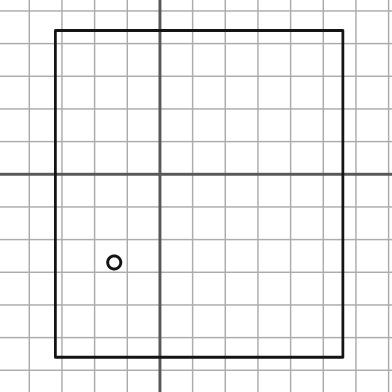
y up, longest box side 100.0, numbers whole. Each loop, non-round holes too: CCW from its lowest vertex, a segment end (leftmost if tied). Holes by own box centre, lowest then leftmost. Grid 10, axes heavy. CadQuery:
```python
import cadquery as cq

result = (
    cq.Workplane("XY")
    .moveTo(-32.0, -56.0)
    .lineTo(56.0, -56.0)
    .lineTo(56.0, 44.0)
    .lineTo(-32.0, 44.0)
    .close()
    .moveTo(-14.0, -27.0)
    .circle(2.0)
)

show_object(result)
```